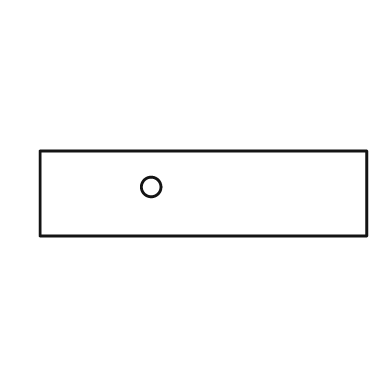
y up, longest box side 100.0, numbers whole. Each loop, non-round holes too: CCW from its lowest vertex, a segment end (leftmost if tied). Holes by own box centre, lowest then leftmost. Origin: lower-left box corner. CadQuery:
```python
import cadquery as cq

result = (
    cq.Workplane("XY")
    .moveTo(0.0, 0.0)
    .lineTo(100.0, 0.0)
    .lineTo(100.0, 26.0)
    .lineTo(0.0, 26.0)
    .close()
    .moveTo(34.0, 15.0)
    .circle(3.0)
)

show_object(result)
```